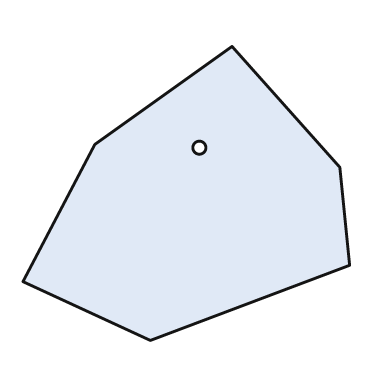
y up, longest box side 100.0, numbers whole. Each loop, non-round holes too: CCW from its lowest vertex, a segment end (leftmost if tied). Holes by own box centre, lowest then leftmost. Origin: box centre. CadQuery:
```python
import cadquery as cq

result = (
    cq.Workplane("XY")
    .moveTo(-11.0, -45.0)
    .lineTo(50.0, -22.0)
    .lineTo(47.0, 8.0)
    .lineTo(14.0, 45.0)
    .lineTo(-28.0, 15.0)
    .lineTo(-50.0, -27.0)
    .close()
    .moveTo(4.0, 14.0)
    .circle(2.0)
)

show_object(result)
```